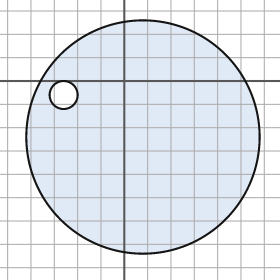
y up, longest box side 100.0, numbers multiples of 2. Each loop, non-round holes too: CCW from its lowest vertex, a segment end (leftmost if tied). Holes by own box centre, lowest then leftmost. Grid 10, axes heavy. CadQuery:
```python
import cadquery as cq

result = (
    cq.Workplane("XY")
    .moveTo(8.0, -24.0)
    .circle(50.0)
    .moveTo(-26.0, -6.0)
    .circle(6.0)
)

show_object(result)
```